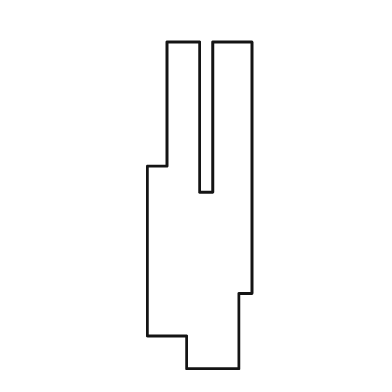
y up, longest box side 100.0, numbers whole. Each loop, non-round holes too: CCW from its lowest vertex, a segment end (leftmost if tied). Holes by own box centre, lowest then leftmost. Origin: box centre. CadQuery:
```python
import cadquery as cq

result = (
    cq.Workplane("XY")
    .moveTo(-4.0, -50.0)
    .lineTo(12.0, -50.0)
    .lineTo(12.0, -27.0)
    .lineTo(16.0, -27.0)
    .lineTo(16.0, 50.0)
    .lineTo(4.0, 50.0)
    .lineTo(4.0, 4.0)
    .lineTo(0.0, 4.0)
    .lineTo(0.0, 50.0)
    .lineTo(-10.0, 50.0)
    .lineTo(-10.0, 12.0)
    .lineTo(-16.0, 12.0)
    .lineTo(-16.0, -40.0)
    .lineTo(-4.0, -40.0)
    .close()
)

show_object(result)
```